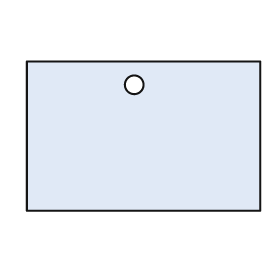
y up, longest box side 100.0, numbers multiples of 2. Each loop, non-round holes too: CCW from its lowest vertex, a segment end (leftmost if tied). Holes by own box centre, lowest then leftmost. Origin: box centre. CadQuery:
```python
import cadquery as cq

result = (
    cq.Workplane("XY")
    .moveTo(-50.0, -32.0)
    .lineTo(50.0, -32.0)
    .lineTo(50.0, 32.0)
    .lineTo(-50.0, 32.0)
    .close()
    .moveTo(-4.0, 22.0)
    .circle(4.0)
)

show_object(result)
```